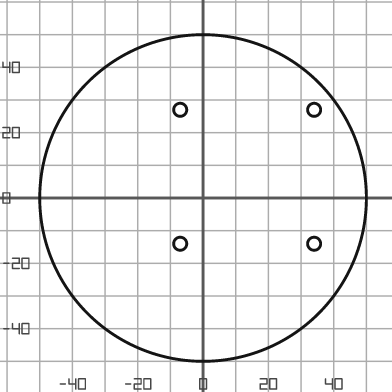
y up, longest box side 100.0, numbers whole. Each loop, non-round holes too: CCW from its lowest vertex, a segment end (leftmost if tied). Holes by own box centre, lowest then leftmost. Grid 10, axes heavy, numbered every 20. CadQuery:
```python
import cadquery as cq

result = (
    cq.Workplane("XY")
    .moveTo(0.0, 0.0)
    .circle(50.0)
    .moveTo(-7.0, -14.0)
    .circle(2.0)
    .moveTo(34.0, -14.0)
    .circle(2.0)
    .moveTo(-7.0, 27.0)
    .circle(2.0)
    .moveTo(34.0, 27.0)
    .circle(2.0)
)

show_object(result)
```